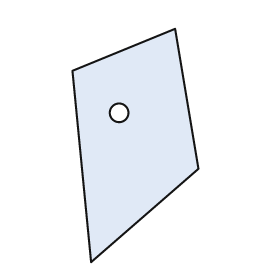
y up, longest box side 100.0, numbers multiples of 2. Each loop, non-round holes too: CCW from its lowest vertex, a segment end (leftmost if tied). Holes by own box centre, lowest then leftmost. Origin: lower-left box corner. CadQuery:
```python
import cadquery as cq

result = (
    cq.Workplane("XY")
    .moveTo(8.0, 0.0)
    .lineTo(54.0, 40.0)
    .lineTo(44.0, 100.0)
    .lineTo(0.0, 82.0)
    .close()
    .moveTo(20.0, 64.0)
    .circle(4.0)
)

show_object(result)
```